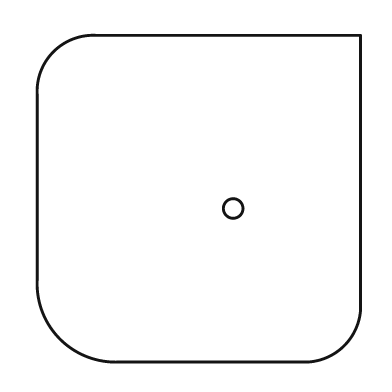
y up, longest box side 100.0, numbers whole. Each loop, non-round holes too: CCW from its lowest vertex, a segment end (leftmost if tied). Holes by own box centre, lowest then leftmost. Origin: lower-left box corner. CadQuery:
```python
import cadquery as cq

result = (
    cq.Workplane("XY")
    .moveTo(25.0, 0.0)
    .lineTo(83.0, 0.0)
    .threePointArc((94.0, 5.0), (99.0, 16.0))
    .lineTo(99.0, 100.0)
    .lineTo(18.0, 100.0)
    .threePointArc((5.0, 95.0), (0.0, 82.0))
    .lineTo(0.0, 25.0)
    .threePointArc((7.0, 7.0), (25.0, 0.0))
    .close()
    .moveTo(60.0, 47.0)
    .circle(3.0)
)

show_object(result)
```